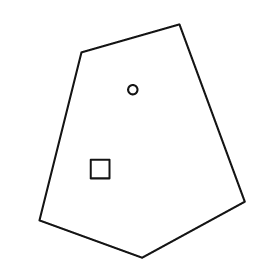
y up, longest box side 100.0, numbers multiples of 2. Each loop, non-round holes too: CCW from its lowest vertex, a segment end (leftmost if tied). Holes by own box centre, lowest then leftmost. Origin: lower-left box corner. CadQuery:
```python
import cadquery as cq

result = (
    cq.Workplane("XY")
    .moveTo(44.0, 0.0)
    .lineTo(88.0, 24.0)
    .lineTo(60.0, 100.0)
    .lineTo(18.0, 88.0)
    .lineTo(0.0, 16.0)
    .close()
    .moveTo(22.0, 34.0)
    .lineTo(30.0, 34.0)
    .lineTo(30.0, 42.0)
    .lineTo(22.0, 42.0)
    .close()
    .moveTo(40.0, 72.0)
    .circle(2.0)
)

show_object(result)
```